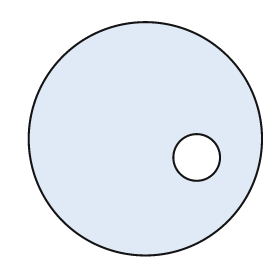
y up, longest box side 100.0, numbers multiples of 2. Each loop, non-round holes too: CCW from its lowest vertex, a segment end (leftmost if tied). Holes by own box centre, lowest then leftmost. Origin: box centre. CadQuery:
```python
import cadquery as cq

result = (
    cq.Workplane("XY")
    .moveTo(0.0, 0.0)
    .circle(50.0)
    .moveTo(22.0, -8.0)
    .circle(10.0)
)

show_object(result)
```